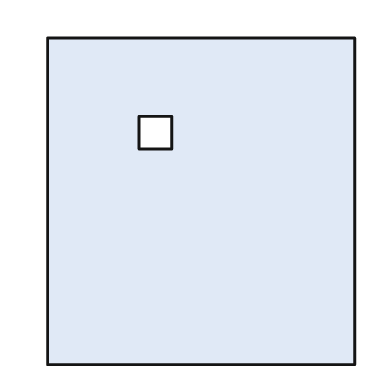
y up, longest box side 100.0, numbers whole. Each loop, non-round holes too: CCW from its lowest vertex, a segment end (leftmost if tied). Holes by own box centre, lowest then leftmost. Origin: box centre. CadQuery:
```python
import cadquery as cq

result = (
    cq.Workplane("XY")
    .moveTo(-47.0, -50.0)
    .lineTo(47.0, -50.0)
    .lineTo(47.0, 50.0)
    .lineTo(-47.0, 50.0)
    .close()
    .moveTo(-19.0, 16.0)
    .lineTo(-9.0, 16.0)
    .lineTo(-9.0, 26.0)
    .lineTo(-19.0, 26.0)
    .close()
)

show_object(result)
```